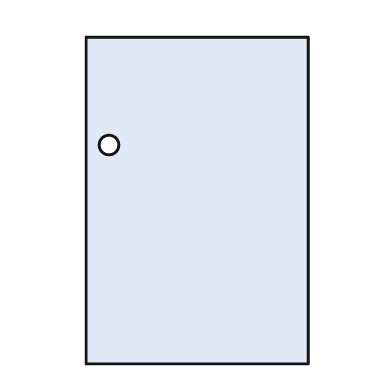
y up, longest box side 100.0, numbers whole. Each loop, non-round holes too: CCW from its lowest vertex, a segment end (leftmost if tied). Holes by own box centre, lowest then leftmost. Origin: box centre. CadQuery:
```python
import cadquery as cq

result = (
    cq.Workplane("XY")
    .moveTo(-34.0, -50.0)
    .lineTo(34.0, -50.0)
    .lineTo(34.0, 50.0)
    .lineTo(-34.0, 50.0)
    .close()
    .moveTo(-27.0, 17.0)
    .circle(3.0)
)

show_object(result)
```